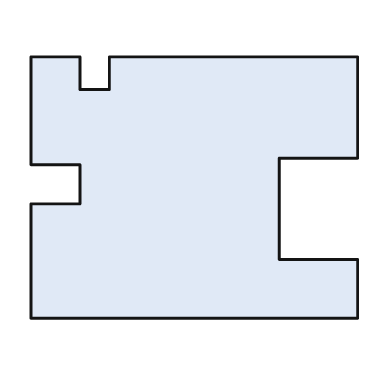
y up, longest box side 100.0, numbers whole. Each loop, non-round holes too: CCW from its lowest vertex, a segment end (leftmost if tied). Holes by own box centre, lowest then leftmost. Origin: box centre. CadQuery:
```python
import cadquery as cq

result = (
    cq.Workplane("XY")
    .moveTo(-50.0, -40.0)
    .lineTo(50.0, -40.0)
    .lineTo(50.0, -22.0)
    .lineTo(26.0, -22.0)
    .lineTo(26.0, 9.0)
    .lineTo(50.0, 9.0)
    .lineTo(50.0, 40.0)
    .lineTo(-26.0, 40.0)
    .lineTo(-26.0, 30.0)
    .lineTo(-35.0, 30.0)
    .lineTo(-35.0, 40.0)
    .lineTo(-50.0, 40.0)
    .lineTo(-50.0, 7.0)
    .lineTo(-35.0, 7.0)
    .lineTo(-35.0, -5.0)
    .lineTo(-50.0, -5.0)
    .close()
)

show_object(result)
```